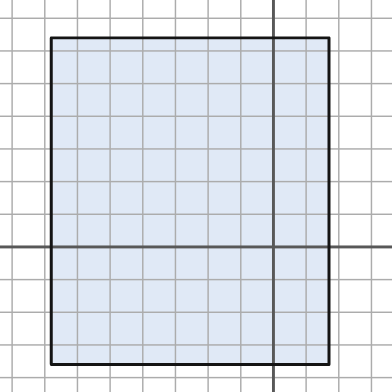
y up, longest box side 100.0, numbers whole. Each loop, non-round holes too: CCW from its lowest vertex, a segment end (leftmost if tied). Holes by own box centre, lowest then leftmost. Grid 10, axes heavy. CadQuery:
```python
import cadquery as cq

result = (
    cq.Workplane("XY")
    .moveTo(-68.0, -36.0)
    .lineTo(17.0, -36.0)
    .lineTo(17.0, 64.0)
    .lineTo(-68.0, 64.0)
    .close()
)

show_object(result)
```